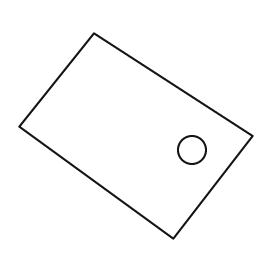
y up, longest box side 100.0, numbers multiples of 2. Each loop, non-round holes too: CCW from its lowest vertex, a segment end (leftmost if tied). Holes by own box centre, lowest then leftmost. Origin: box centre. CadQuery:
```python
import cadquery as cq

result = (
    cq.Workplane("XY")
    .moveTo(16.0, -44.0)
    .lineTo(50.0, 0.0)
    .lineTo(-18.0, 44.0)
    .lineTo(-50.0, 4.0)
    .close()
    .moveTo(24.0, -6.0)
    .circle(6.0)
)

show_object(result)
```